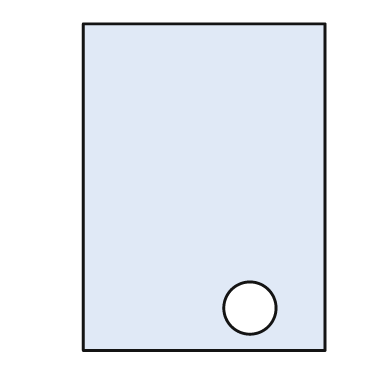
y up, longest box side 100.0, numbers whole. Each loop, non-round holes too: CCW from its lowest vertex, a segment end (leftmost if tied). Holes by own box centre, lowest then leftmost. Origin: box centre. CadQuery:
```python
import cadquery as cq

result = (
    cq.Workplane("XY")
    .moveTo(-37.0, -50.0)
    .lineTo(37.0, -50.0)
    .lineTo(37.0, 50.0)
    .lineTo(-37.0, 50.0)
    .close()
    .moveTo(14.0, -37.0)
    .circle(8.0)
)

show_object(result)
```